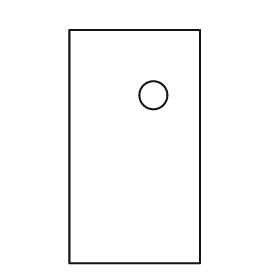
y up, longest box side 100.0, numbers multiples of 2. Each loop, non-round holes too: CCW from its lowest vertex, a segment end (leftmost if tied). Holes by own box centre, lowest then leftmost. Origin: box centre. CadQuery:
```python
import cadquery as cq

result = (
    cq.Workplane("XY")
    .moveTo(-28.0, -50.0)
    .lineTo(28.0, -50.0)
    .lineTo(28.0, 50.0)
    .lineTo(-28.0, 50.0)
    .close()
    .moveTo(8.0, 22.0)
    .circle(6.0)
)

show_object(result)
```